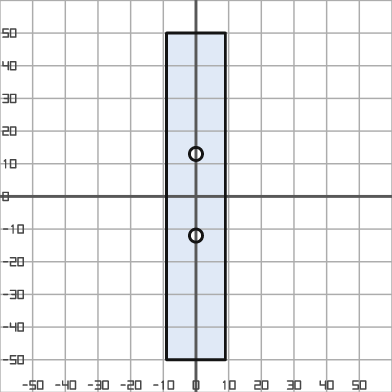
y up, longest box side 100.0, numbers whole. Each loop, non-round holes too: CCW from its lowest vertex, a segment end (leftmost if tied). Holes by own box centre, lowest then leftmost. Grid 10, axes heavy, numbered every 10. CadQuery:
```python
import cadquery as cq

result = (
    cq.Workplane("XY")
    .moveTo(-9.0, -50.0)
    .lineTo(9.0, -50.0)
    .lineTo(9.0, 50.0)
    .lineTo(-9.0, 50.0)
    .close()
    .moveTo(0.0, -12.0)
    .circle(2.0)
    .moveTo(0.0, 13.0)
    .circle(2.0)
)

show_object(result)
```